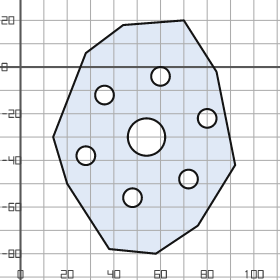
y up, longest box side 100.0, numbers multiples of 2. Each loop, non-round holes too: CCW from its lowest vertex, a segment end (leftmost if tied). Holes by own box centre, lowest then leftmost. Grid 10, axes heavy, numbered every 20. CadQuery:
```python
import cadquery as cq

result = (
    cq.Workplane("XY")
    .moveTo(58.0, -80.0)
    .lineTo(76.0, -68.0)
    .lineTo(92.0, -42.0)
    .lineTo(84.0, -2.0)
    .lineTo(70.0, 20.0)
    .lineTo(44.0, 18.0)
    .lineTo(28.0, 6.0)
    .lineTo(14.0, -30.0)
    .lineTo(20.0, -50.0)
    .lineTo(38.0, -78.0)
    .close()
    .moveTo(48.0, -56.0)
    .circle(4.0)
    .moveTo(72.0, -48.0)
    .circle(4.0)
    .moveTo(28.0, -38.0)
    .circle(4.0)
    .moveTo(54.0, -30.0)
    .circle(8.0)
    .moveTo(80.0, -22.0)
    .circle(4.0)
    .moveTo(36.0, -12.0)
    .circle(4.0)
    .moveTo(60.0, -4.0)
    .circle(4.0)
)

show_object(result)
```